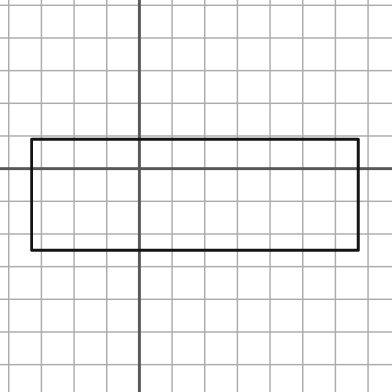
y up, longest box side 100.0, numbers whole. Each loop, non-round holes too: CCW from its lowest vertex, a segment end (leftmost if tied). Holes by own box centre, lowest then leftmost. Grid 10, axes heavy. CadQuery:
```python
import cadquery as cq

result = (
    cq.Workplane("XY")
    .moveTo(-33.0, -25.0)
    .lineTo(67.0, -25.0)
    .lineTo(67.0, 9.0)
    .lineTo(-33.0, 9.0)
    .close()
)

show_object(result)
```